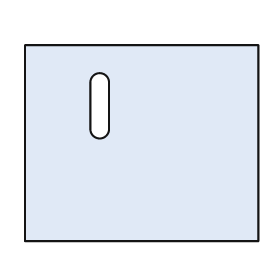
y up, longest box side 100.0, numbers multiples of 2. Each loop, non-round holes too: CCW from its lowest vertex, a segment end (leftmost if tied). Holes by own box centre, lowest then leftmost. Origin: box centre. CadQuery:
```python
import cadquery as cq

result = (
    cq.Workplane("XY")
    .moveTo(-50.0, -42.0)
    .lineTo(50.0, -42.0)
    .lineTo(50.0, 42.0)
    .lineTo(-50.0, 42.0)
    .close()
    .moveTo(-22.0, 6.0)
    .threePointArc((-18.0, 2.0), (-14.0, 6.0))
    .lineTo(-14.0, 26.0)
    .threePointArc((-18.0, 30.0), (-22.0, 26.0))
    .close()
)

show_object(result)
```